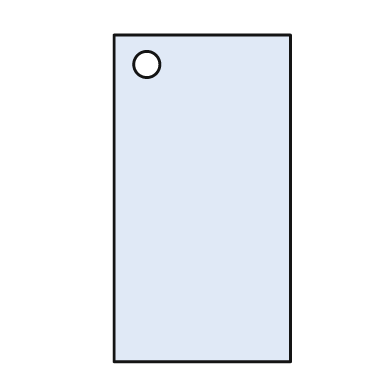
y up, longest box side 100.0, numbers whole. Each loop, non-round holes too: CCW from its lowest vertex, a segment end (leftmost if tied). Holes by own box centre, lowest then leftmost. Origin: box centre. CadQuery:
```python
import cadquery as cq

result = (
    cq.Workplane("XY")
    .moveTo(-27.0, -50.0)
    .lineTo(27.0, -50.0)
    .lineTo(27.0, 50.0)
    .lineTo(-27.0, 50.0)
    .close()
    .moveTo(-17.0, 41.0)
    .circle(4.0)
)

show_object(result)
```